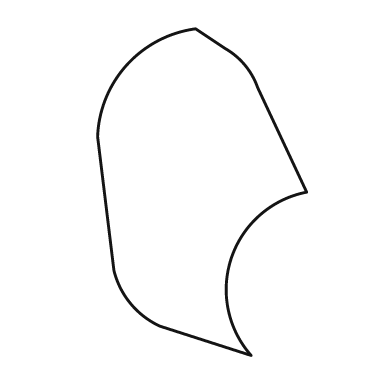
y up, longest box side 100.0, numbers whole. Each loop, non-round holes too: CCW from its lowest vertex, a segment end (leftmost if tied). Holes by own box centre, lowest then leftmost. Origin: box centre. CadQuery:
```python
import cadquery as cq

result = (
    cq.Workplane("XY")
    .moveTo(15.0, -50.0)
    .threePointArc((9.0, -20.0), (32.0, 0.0))
    .lineTo(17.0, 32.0)
    .threePointArc((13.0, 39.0), (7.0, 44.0))
    .lineTo(-2.0, 50.0)
    .threePointArc((-23.0, 39.0), (-32.0, 17.0))
    .lineTo(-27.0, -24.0)
    .threePointArc((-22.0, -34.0), (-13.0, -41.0))
    .close()
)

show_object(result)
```